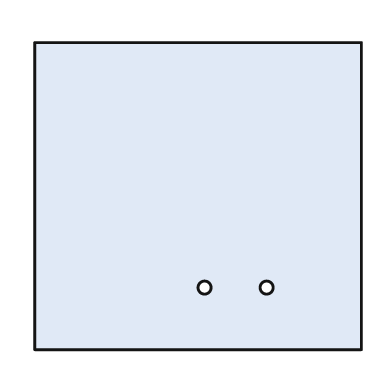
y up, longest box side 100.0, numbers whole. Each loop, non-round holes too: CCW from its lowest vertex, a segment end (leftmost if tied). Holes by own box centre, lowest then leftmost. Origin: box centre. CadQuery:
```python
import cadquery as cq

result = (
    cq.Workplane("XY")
    .moveTo(-50.0, -47.0)
    .lineTo(50.0, -47.0)
    .lineTo(50.0, 47.0)
    .lineTo(-50.0, 47.0)
    .close()
    .moveTo(2.0, -28.0)
    .circle(2.0)
    .moveTo(21.0, -28.0)
    .circle(2.0)
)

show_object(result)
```